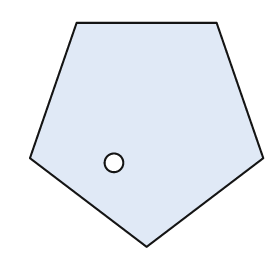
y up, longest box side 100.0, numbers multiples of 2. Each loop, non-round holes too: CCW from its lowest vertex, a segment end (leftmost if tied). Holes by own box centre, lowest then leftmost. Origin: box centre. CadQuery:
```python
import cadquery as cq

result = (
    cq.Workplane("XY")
    .moveTo(0.0, -48.0)
    .lineTo(50.0, -10.0)
    .lineTo(30.0, 48.0)
    .lineTo(-30.0, 48.0)
    .lineTo(-50.0, -10.0)
    .close()
    .moveTo(-14.0, -12.0)
    .circle(4.0)
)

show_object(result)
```